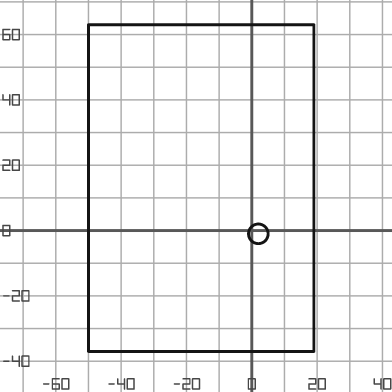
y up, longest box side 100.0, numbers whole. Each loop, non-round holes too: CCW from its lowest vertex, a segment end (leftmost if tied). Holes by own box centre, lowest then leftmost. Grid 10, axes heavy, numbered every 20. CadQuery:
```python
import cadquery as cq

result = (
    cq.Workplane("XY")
    .moveTo(-50.0, -37.0)
    .lineTo(19.0, -37.0)
    .lineTo(19.0, 63.0)
    .lineTo(-50.0, 63.0)
    .close()
    .moveTo(2.0, -1.0)
    .circle(3.0)
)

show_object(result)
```